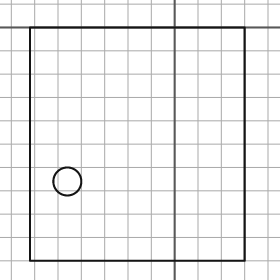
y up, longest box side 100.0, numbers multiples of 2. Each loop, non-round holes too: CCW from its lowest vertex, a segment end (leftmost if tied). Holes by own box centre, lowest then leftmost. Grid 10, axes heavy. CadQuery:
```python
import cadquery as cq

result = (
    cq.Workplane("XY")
    .moveTo(-62.0, -100.0)
    .lineTo(30.0, -100.0)
    .lineTo(30.0, 0.0)
    .lineTo(-62.0, 0.0)
    .close()
    .moveTo(-46.0, -66.0)
    .circle(6.0)
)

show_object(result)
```